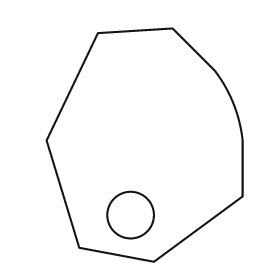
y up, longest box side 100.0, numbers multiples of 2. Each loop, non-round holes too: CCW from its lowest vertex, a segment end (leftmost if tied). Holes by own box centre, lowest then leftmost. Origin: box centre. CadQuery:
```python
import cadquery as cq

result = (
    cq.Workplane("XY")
    .moveTo(4.0, -50.0)
    .lineTo(42.0, -22.0)
    .lineTo(42.0, 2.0)
    .threePointArc((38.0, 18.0), (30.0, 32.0))
    .lineTo(12.0, 50.0)
    .lineTo(-20.0, 48.0)
    .lineTo(-42.0, 2.0)
    .lineTo(-28.0, -44.0)
    .close()
    .moveTo(-6.0, -30.0)
    .circle(10.0)
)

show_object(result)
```